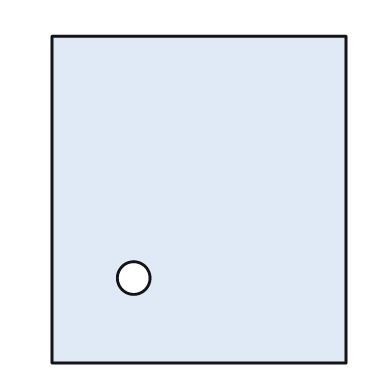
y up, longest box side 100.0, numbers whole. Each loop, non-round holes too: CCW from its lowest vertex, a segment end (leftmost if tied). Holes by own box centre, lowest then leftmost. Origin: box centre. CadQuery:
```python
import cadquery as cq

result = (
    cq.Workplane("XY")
    .moveTo(-45.0, -50.0)
    .lineTo(45.0, -50.0)
    .lineTo(45.0, 50.0)
    .lineTo(-45.0, 50.0)
    .close()
    .moveTo(-20.0, -24.0)
    .circle(5.0)
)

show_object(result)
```